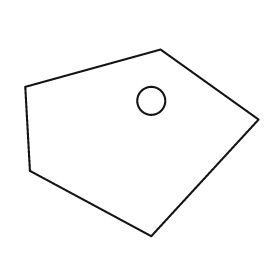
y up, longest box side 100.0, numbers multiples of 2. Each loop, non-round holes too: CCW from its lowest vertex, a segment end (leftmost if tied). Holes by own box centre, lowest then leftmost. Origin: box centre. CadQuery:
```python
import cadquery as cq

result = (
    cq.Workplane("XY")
    .moveTo(4.0, -40.0)
    .lineTo(50.0, 10.0)
    .lineTo(8.0, 40.0)
    .lineTo(-50.0, 24.0)
    .lineTo(-48.0, -12.0)
    .close()
    .moveTo(4.0, 18.0)
    .circle(6.0)
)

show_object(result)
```